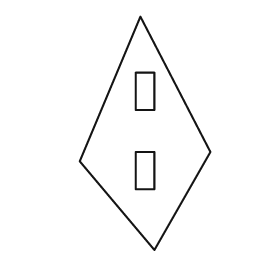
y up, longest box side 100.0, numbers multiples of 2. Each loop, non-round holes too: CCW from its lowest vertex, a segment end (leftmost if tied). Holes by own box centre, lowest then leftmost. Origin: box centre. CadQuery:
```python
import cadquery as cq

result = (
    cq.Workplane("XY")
    .moveTo(4.0, -50.0)
    .lineTo(28.0, -8.0)
    .lineTo(-2.0, 50.0)
    .lineTo(-28.0, -12.0)
    .close()
    .moveTo(-4.0, -24.0)
    .lineTo(4.0, -24.0)
    .lineTo(4.0, -8.0)
    .lineTo(-4.0, -8.0)
    .close()
    .moveTo(-4.0, 10.0)
    .lineTo(4.0, 10.0)
    .lineTo(4.0, 26.0)
    .lineTo(-4.0, 26.0)
    .close()
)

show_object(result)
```